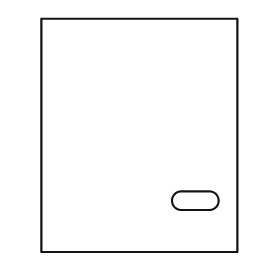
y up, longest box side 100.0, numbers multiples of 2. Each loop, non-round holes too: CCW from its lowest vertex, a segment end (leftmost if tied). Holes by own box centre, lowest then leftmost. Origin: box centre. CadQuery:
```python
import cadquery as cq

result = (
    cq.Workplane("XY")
    .moveTo(-42.0, -50.0)
    .lineTo(42.0, -50.0)
    .lineTo(42.0, 50.0)
    .lineTo(-42.0, 50.0)
    .close()
    .moveTo(18.0, -32.0)
    .lineTo(30.0, -32.0)
    .threePointArc((34.0, -28.0), (30.0, -24.0))
    .lineTo(18.0, -24.0)
    .threePointArc((14.0, -28.0), (18.0, -32.0))
    .close()
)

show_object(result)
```